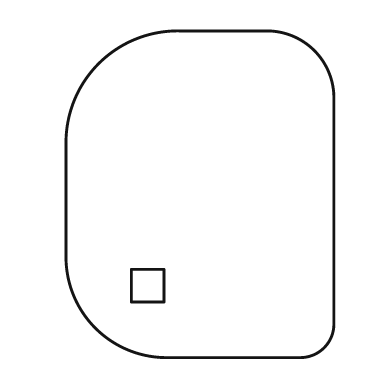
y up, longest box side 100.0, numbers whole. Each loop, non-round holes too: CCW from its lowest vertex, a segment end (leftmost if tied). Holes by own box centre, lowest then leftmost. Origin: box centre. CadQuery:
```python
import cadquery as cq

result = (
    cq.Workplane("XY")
    .moveTo(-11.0, -50.0)
    .lineTo(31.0, -50.0)
    .threePointArc((38.0, -47.0), (41.0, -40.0))
    .lineTo(41.0, 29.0)
    .threePointArc((35.0, 44.0), (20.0, 50.0))
    .lineTo(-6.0, 50.0)
    .threePointArc((-31.0, 40.0), (-41.0, 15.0))
    .lineTo(-41.0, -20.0)
    .threePointArc((-32.0, -41.0), (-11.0, -50.0))
    .close()
    .moveTo(-21.0, -33.0)
    .lineTo(-11.0, -33.0)
    .lineTo(-11.0, -23.0)
    .lineTo(-21.0, -23.0)
    .close()
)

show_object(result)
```